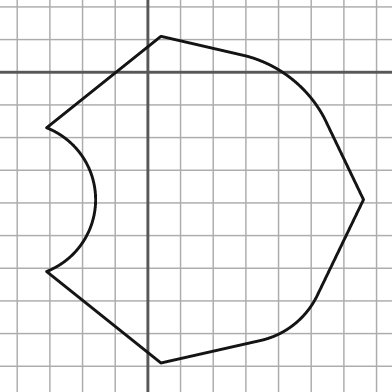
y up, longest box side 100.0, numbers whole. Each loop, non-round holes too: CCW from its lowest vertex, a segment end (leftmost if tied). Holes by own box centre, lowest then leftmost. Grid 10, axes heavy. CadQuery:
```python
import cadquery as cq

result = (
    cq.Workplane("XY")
    .moveTo(4.0, -89.0)
    .lineTo(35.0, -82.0)
    .threePointArc((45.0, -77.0), (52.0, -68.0))
    .lineTo(66.0, -39.0)
    .lineTo(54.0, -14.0)
    .threePointArc((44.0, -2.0), (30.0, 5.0))
    .lineTo(4.0, 11.0)
    .lineTo(-31.0, -17.0)
    .threePointArc((-16.0, -39.0), (-31.0, -61.0))
    .close()
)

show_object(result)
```